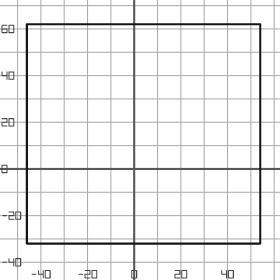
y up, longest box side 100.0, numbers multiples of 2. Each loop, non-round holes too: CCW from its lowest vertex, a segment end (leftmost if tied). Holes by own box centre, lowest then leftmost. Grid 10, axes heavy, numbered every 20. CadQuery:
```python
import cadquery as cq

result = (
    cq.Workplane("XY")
    .moveTo(-46.0, -32.0)
    .lineTo(54.0, -32.0)
    .lineTo(54.0, 62.0)
    .lineTo(-46.0, 62.0)
    .close()
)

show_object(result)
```